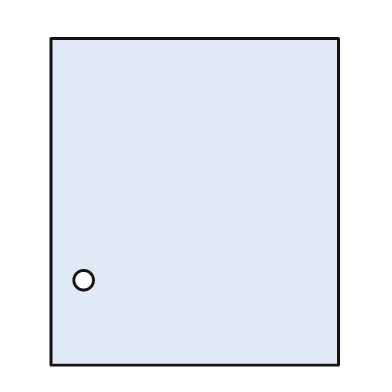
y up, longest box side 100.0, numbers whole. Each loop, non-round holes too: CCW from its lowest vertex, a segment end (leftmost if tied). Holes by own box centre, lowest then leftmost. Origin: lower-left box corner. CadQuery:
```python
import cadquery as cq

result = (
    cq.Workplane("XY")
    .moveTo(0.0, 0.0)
    .lineTo(88.0, 0.0)
    .lineTo(88.0, 100.0)
    .lineTo(0.0, 100.0)
    .close()
    .moveTo(10.0, 26.0)
    .circle(3.0)
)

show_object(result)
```